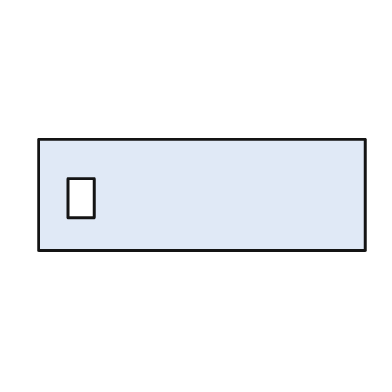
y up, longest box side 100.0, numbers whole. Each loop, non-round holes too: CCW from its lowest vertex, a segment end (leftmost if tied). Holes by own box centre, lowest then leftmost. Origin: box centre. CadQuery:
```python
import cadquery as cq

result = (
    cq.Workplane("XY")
    .moveTo(-50.0, -17.0)
    .lineTo(50.0, -17.0)
    .lineTo(50.0, 17.0)
    .lineTo(-50.0, 17.0)
    .close()
    .moveTo(-41.0, -7.0)
    .lineTo(-33.0, -7.0)
    .lineTo(-33.0, 5.0)
    .lineTo(-41.0, 5.0)
    .close()
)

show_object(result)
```